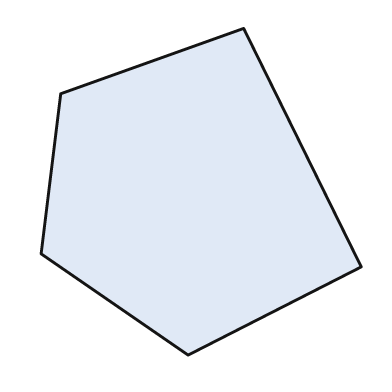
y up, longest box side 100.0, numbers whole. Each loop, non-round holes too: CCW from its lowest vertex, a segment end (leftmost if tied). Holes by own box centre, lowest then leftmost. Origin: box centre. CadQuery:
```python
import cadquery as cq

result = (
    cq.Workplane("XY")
    .moveTo(-4.0, -50.0)
    .lineTo(49.0, -23.0)
    .lineTo(13.0, 50.0)
    .lineTo(-43.0, 30.0)
    .lineTo(-49.0, -19.0)
    .close()
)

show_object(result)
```